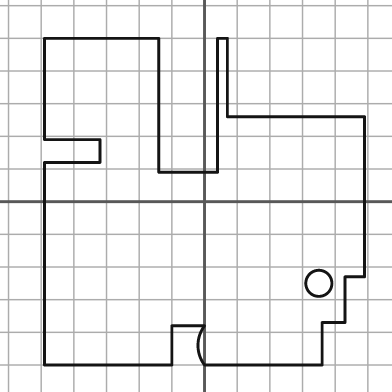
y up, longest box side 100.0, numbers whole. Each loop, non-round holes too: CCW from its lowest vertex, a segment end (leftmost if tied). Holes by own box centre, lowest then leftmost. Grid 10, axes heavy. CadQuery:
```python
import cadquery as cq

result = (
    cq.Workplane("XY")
    .moveTo(-49.0, -50.0)
    .lineTo(-10.0, -50.0)
    .lineTo(-10.0, -38.0)
    .lineTo(0.0, -38.0)
    .threePointArc((-2.0, -44.0), (0.0, -50.0))
    .lineTo(36.0, -50.0)
    .lineTo(36.0, -37.0)
    .lineTo(43.0, -37.0)
    .lineTo(43.0, -23.0)
    .lineTo(49.0, -23.0)
    .lineTo(49.0, 26.0)
    .lineTo(7.0, 26.0)
    .lineTo(7.0, 50.0)
    .lineTo(4.0, 50.0)
    .lineTo(4.0, 9.0)
    .lineTo(-14.0, 9.0)
    .lineTo(-14.0, 50.0)
    .lineTo(-49.0, 50.0)
    .lineTo(-49.0, 19.0)
    .lineTo(-32.0, 19.0)
    .lineTo(-32.0, 12.0)
    .lineTo(-49.0, 12.0)
    .close()
    .moveTo(35.0, -25.0)
    .circle(4.0)
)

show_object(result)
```